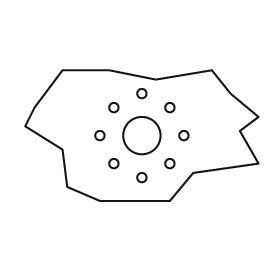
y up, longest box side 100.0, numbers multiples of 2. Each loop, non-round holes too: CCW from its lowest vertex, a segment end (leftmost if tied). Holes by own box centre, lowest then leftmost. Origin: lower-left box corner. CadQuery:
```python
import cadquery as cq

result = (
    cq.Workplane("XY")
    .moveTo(32.0, 0.0)
    .lineTo(62.0, 0.0)
    .lineTo(72.0, 12.0)
    .lineTo(100.0, 16.0)
    .lineTo(92.0, 30.0)
    .lineTo(100.0, 36.0)
    .lineTo(88.0, 46.0)
    .lineTo(80.0, 56.0)
    .lineTo(56.0, 52.0)
    .lineTo(36.0, 56.0)
    .lineTo(16.0, 56.0)
    .lineTo(4.0, 40.0)
    .lineTo(0.0, 32.0)
    .lineTo(16.0, 22.0)
    .lineTo(18.0, 6.0)
    .close()
    .moveTo(50.0, 10.0)
    .circle(2.0)
    .moveTo(38.0, 16.0)
    .circle(2.0)
    .moveTo(62.0, 16.0)
    .circle(2.0)
    .moveTo(32.0, 28.0)
    .circle(2.0)
    .moveTo(50.0, 28.0)
    .circle(8.0)
    .moveTo(68.0, 28.0)
    .circle(2.0)
    .moveTo(38.0, 40.0)
    .circle(2.0)
    .moveTo(62.0, 40.0)
    .circle(2.0)
    .moveTo(50.0, 46.0)
    .circle(2.0)
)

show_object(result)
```